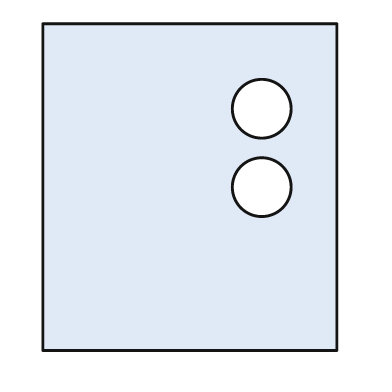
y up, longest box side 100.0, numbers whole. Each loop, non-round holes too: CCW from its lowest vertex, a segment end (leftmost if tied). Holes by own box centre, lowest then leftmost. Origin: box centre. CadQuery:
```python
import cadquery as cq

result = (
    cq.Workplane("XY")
    .moveTo(-45.0, -50.0)
    .lineTo(45.0, -50.0)
    .lineTo(45.0, 50.0)
    .lineTo(-45.0, 50.0)
    .close()
    .moveTo(22.0, 0.0)
    .circle(9.0)
    .moveTo(22.0, 24.0)
    .circle(9.0)
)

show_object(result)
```